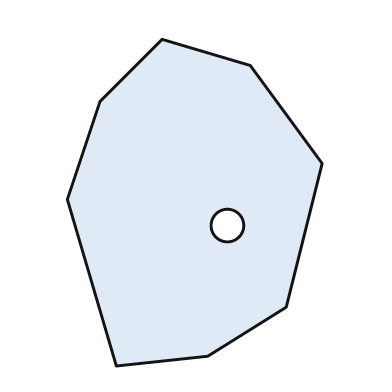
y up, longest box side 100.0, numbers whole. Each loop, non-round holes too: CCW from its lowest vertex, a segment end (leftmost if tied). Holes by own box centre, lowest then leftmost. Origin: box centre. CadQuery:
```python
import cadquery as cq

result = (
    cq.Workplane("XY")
    .moveTo(-24.0, -50.0)
    .lineTo(4.0, -47.0)
    .lineTo(28.0, -32.0)
    .lineTo(39.0, 12.0)
    .lineTo(17.0, 42.0)
    .lineTo(-10.0, 50.0)
    .lineTo(-29.0, 31.0)
    .lineTo(-39.0, 1.0)
    .close()
    .moveTo(10.0, -7.0)
    .circle(5.0)
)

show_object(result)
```